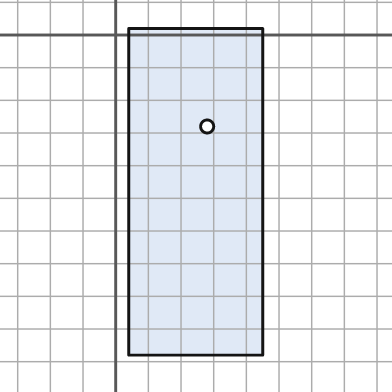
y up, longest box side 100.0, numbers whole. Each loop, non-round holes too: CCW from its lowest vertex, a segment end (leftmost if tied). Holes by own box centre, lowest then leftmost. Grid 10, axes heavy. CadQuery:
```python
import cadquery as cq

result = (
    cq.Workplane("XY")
    .moveTo(4.0, -98.0)
    .lineTo(45.0, -98.0)
    .lineTo(45.0, 2.0)
    .lineTo(4.0, 2.0)
    .close()
    .moveTo(28.0, -28.0)
    .circle(2.0)
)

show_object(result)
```